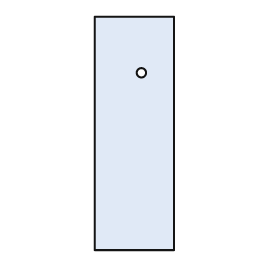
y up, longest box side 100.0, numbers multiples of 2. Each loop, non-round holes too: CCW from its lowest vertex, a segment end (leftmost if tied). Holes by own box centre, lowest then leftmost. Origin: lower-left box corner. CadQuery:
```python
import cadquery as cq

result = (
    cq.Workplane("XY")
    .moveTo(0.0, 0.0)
    .lineTo(34.0, 0.0)
    .lineTo(34.0, 100.0)
    .lineTo(0.0, 100.0)
    .close()
    .moveTo(20.0, 76.0)
    .circle(2.0)
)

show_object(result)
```